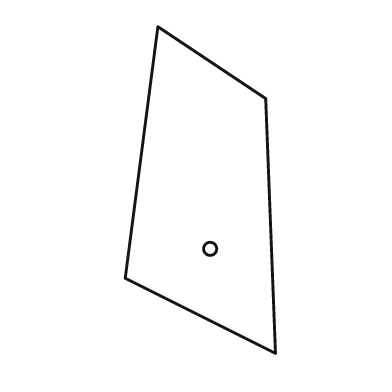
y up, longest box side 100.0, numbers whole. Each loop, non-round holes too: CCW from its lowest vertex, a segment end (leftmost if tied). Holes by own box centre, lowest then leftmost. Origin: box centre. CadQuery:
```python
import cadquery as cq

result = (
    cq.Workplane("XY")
    .moveTo(23.0, -50.0)
    .lineTo(20.0, 28.0)
    .lineTo(-13.0, 50.0)
    .lineTo(-23.0, -27.0)
    .close()
    .moveTo(3.0, -18.0)
    .circle(2.0)
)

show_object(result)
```